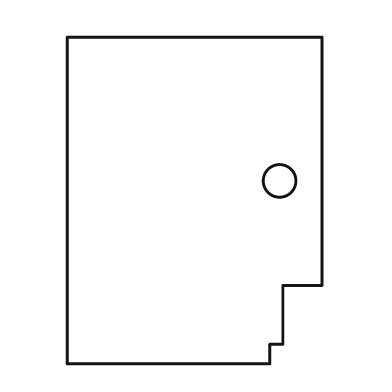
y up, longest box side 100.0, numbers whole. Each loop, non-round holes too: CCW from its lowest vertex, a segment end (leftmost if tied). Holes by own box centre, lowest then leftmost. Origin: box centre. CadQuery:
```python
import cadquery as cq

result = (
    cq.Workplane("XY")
    .moveTo(-39.0, -50.0)
    .lineTo(23.0, -50.0)
    .lineTo(23.0, -44.0)
    .lineTo(27.0, -44.0)
    .lineTo(27.0, -26.0)
    .lineTo(39.0, -26.0)
    .lineTo(39.0, 50.0)
    .lineTo(-39.0, 50.0)
    .close()
    .moveTo(26.0, 6.0)
    .circle(5.0)
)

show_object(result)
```